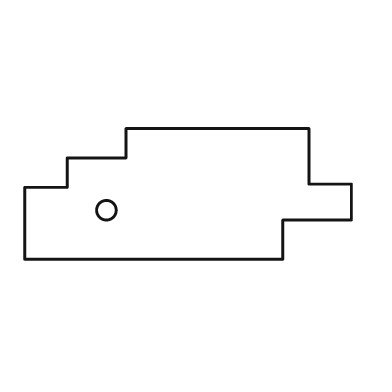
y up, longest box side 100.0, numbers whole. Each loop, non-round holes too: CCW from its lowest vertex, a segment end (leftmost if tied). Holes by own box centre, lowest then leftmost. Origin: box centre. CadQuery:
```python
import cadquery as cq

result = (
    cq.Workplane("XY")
    .moveTo(-50.0, -20.0)
    .lineTo(29.0, -20.0)
    .lineTo(29.0, -8.0)
    .lineTo(50.0, -8.0)
    .lineTo(50.0, 3.0)
    .lineTo(37.0, 3.0)
    .lineTo(37.0, 20.0)
    .lineTo(-19.0, 20.0)
    .lineTo(-19.0, 11.0)
    .lineTo(-37.0, 11.0)
    .lineTo(-37.0, 2.0)
    .lineTo(-50.0, 2.0)
    .close()
    .moveTo(-25.0, -5.0)
    .circle(3.0)
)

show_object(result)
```